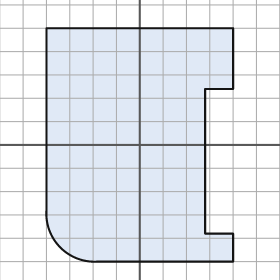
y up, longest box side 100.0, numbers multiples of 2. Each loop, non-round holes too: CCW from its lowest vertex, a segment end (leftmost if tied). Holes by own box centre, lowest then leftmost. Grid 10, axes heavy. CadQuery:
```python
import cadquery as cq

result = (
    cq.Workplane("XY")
    .moveTo(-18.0, -50.0)
    .lineTo(40.0, -50.0)
    .lineTo(40.0, -38.0)
    .lineTo(28.0, -38.0)
    .lineTo(28.0, 24.0)
    .lineTo(40.0, 24.0)
    .lineTo(40.0, 50.0)
    .lineTo(-40.0, 50.0)
    .lineTo(-40.0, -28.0)
    .threePointArc((-34.0, -44.0), (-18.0, -50.0))
    .close()
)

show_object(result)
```